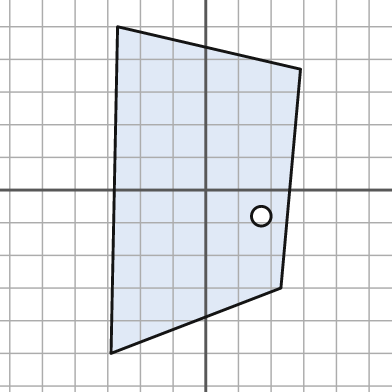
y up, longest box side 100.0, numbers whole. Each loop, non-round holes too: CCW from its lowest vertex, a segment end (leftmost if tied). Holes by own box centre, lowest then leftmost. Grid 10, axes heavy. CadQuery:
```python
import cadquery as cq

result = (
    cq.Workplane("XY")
    .moveTo(-29.0, -50.0)
    .lineTo(23.0, -30.0)
    .lineTo(29.0, 37.0)
    .lineTo(-27.0, 50.0)
    .close()
    .moveTo(17.0, -8.0)
    .circle(3.0)
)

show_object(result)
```